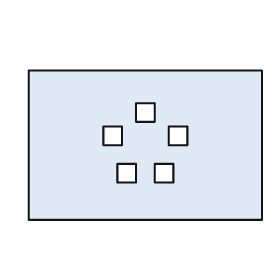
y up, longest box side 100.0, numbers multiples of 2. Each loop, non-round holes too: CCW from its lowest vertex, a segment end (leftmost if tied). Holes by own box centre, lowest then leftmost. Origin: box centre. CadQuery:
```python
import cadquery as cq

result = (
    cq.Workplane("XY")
    .moveTo(-50.0, -32.0)
    .lineTo(50.0, -32.0)
    .lineTo(50.0, 32.0)
    .lineTo(-50.0, 32.0)
    .close()
    .moveTo(-12.0, -16.0)
    .lineTo(-4.0, -16.0)
    .lineTo(-4.0, -8.0)
    .lineTo(-12.0, -8.0)
    .close()
    .moveTo(4.0, -16.0)
    .lineTo(12.0, -16.0)
    .lineTo(12.0, -8.0)
    .lineTo(4.0, -8.0)
    .close()
    .moveTo(-18.0, 0.0)
    .lineTo(-10.0, 0.0)
    .lineTo(-10.0, 8.0)
    .lineTo(-18.0, 8.0)
    .close()
    .moveTo(10.0, 0.0)
    .lineTo(18.0, 0.0)
    .lineTo(18.0, 8.0)
    .lineTo(10.0, 8.0)
    .close()
    .moveTo(-4.0, 10.0)
    .lineTo(4.0, 10.0)
    .lineTo(4.0, 18.0)
    .lineTo(-4.0, 18.0)
    .close()
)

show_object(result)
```